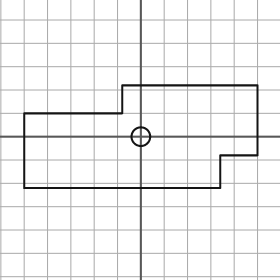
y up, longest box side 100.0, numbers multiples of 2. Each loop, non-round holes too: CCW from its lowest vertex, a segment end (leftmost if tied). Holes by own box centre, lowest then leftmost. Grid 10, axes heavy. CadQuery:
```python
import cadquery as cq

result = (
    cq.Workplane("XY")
    .moveTo(-50.0, -22.0)
    .lineTo(34.0, -22.0)
    .lineTo(34.0, -8.0)
    .lineTo(50.0, -8.0)
    .lineTo(50.0, 22.0)
    .lineTo(-8.0, 22.0)
    .lineTo(-8.0, 10.0)
    .lineTo(-50.0, 10.0)
    .close()
    .moveTo(0.0, 0.0)
    .circle(4.0)
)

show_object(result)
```